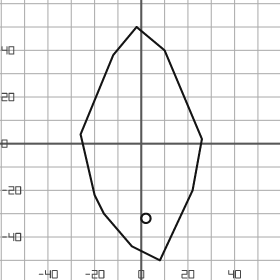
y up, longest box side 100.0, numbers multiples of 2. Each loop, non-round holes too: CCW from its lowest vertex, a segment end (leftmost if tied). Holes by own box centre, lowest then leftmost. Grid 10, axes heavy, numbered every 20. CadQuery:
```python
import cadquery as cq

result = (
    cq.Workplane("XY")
    .moveTo(8.0, -50.0)
    .lineTo(22.0, -20.0)
    .lineTo(26.0, 2.0)
    .lineTo(10.0, 40.0)
    .lineTo(-2.0, 50.0)
    .lineTo(-12.0, 38.0)
    .lineTo(-26.0, 4.0)
    .lineTo(-20.0, -22.0)
    .lineTo(-16.0, -30.0)
    .lineTo(-4.0, -44.0)
    .close()
    .moveTo(2.0, -32.0)
    .circle(2.0)
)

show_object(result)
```